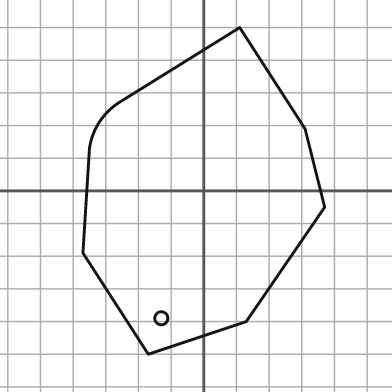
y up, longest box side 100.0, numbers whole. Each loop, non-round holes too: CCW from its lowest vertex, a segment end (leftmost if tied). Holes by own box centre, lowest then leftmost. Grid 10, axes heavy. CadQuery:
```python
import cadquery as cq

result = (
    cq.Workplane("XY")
    .moveTo(-17.0, -50.0)
    .lineTo(13.0, -40.0)
    .lineTo(37.0, -5.0)
    .lineTo(31.0, 19.0)
    .lineTo(11.0, 50.0)
    .lineTo(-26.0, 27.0)
    .threePointArc((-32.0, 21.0), (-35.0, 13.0))
    .lineTo(-37.0, -19.0)
    .close()
    .moveTo(-13.0, -39.0)
    .circle(2.0)
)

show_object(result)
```